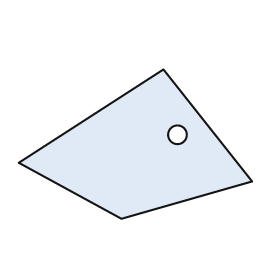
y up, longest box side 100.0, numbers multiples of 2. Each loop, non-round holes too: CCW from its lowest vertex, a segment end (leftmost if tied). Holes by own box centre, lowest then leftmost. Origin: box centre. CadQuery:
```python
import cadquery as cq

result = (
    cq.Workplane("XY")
    .moveTo(-6.0, -32.0)
    .lineTo(50.0, -16.0)
    .lineTo(12.0, 32.0)
    .lineTo(-50.0, -8.0)
    .close()
    .moveTo(18.0, 4.0)
    .circle(4.0)
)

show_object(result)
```